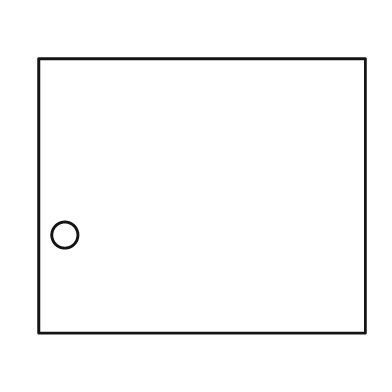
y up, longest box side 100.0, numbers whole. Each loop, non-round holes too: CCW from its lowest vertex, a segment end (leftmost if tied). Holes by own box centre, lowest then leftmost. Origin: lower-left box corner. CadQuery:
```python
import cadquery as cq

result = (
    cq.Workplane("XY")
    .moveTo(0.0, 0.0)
    .lineTo(100.0, 0.0)
    .lineTo(100.0, 84.0)
    .lineTo(0.0, 84.0)
    .close()
    .moveTo(8.0, 30.0)
    .circle(4.0)
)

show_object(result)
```